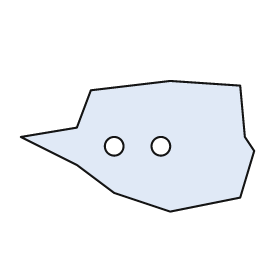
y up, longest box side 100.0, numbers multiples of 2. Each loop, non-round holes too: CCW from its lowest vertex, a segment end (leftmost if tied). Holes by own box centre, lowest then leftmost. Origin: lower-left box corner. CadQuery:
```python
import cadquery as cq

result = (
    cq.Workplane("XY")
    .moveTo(64.0, 0.0)
    .lineTo(94.0, 6.0)
    .lineTo(100.0, 26.0)
    .lineTo(96.0, 32.0)
    .lineTo(94.0, 54.0)
    .lineTo(64.0, 56.0)
    .lineTo(30.0, 52.0)
    .lineTo(24.0, 36.0)
    .lineTo(0.0, 32.0)
    .lineTo(24.0, 20.0)
    .lineTo(40.0, 8.0)
    .close()
    .moveTo(40.0, 28.0)
    .circle(4.0)
    .moveTo(60.0, 28.0)
    .circle(4.0)
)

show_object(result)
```